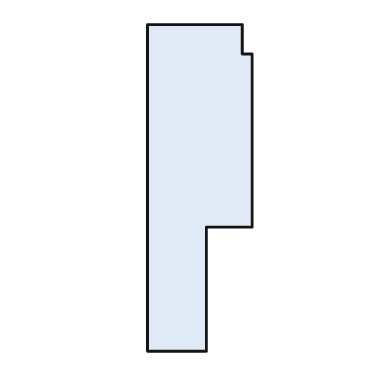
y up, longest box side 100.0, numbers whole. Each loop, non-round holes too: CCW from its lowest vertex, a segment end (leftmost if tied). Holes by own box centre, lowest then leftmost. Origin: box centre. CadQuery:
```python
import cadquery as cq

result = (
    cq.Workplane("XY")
    .moveTo(-16.0, -50.0)
    .lineTo(2.0, -50.0)
    .lineTo(2.0, -12.0)
    .lineTo(16.0, -12.0)
    .lineTo(16.0, 41.0)
    .lineTo(13.0, 41.0)
    .lineTo(13.0, 50.0)
    .lineTo(-16.0, 50.0)
    .close()
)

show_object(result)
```